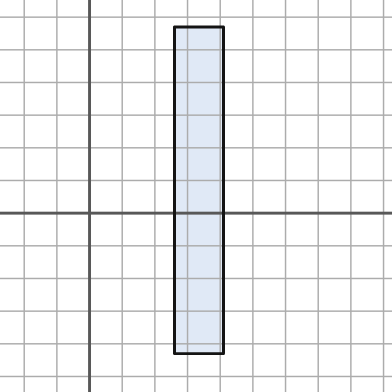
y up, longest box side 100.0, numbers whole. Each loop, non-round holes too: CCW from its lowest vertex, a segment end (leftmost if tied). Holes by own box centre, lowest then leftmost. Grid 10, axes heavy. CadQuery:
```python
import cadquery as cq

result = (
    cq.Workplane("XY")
    .moveTo(26.0, -43.0)
    .lineTo(41.0, -43.0)
    .lineTo(41.0, 57.0)
    .lineTo(26.0, 57.0)
    .close()
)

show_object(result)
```